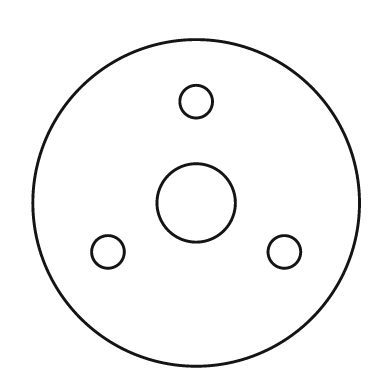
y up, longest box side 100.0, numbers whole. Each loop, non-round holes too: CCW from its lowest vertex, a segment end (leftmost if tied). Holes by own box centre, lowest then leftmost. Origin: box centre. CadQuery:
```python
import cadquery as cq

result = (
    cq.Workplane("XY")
    .moveTo(0.0, 0.0)
    .circle(50.0)
    .moveTo(-27.0, -15.0)
    .circle(5.0)
    .moveTo(27.0, -15.0)
    .circle(5.0)
    .moveTo(0.0, 0.0)
    .circle(12.0)
    .moveTo(0.0, 31.0)
    .circle(5.0)
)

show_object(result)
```